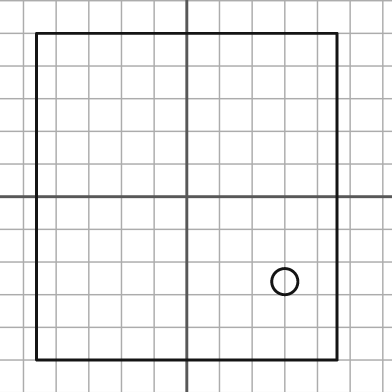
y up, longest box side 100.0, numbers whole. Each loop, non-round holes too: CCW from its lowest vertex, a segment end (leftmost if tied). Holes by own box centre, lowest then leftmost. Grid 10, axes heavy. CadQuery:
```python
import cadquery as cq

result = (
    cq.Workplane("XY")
    .moveTo(-46.0, -50.0)
    .lineTo(46.0, -50.0)
    .lineTo(46.0, 50.0)
    .lineTo(-46.0, 50.0)
    .close()
    .moveTo(30.0, -26.0)
    .circle(4.0)
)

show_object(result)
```